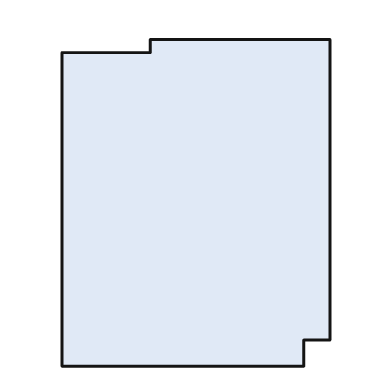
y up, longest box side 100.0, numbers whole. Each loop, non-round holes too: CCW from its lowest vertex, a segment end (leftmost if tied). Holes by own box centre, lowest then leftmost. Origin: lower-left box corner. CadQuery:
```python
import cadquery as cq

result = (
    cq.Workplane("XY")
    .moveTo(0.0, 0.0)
    .lineTo(74.0, 0.0)
    .lineTo(74.0, 8.0)
    .lineTo(82.0, 8.0)
    .lineTo(82.0, 100.0)
    .lineTo(27.0, 100.0)
    .lineTo(27.0, 96.0)
    .lineTo(0.0, 96.0)
    .close()
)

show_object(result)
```